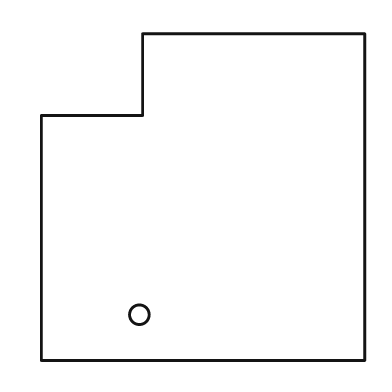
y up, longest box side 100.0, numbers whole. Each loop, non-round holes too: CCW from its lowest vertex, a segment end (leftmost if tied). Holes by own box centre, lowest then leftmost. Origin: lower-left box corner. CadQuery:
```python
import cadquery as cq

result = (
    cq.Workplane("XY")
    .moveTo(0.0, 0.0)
    .lineTo(99.0, 0.0)
    .lineTo(99.0, 100.0)
    .lineTo(31.0, 100.0)
    .lineTo(31.0, 75.0)
    .lineTo(0.0, 75.0)
    .close()
    .moveTo(30.0, 14.0)
    .circle(3.0)
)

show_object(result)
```